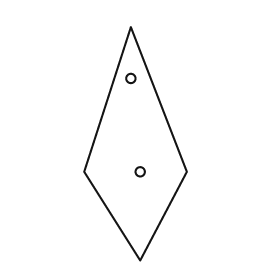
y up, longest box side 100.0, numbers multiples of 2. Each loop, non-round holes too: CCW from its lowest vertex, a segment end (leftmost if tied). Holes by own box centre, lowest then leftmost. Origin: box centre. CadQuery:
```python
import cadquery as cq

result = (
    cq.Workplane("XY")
    .moveTo(2.0, -50.0)
    .lineTo(22.0, -12.0)
    .lineTo(-2.0, 50.0)
    .lineTo(-22.0, -12.0)
    .close()
    .moveTo(2.0, -12.0)
    .circle(2.0)
    .moveTo(-2.0, 28.0)
    .circle(2.0)
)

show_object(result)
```